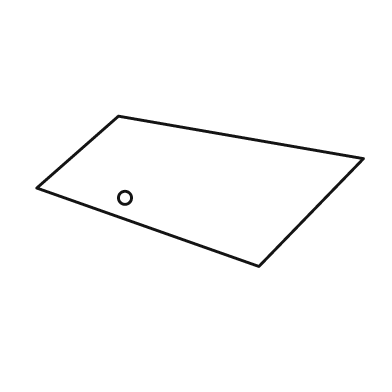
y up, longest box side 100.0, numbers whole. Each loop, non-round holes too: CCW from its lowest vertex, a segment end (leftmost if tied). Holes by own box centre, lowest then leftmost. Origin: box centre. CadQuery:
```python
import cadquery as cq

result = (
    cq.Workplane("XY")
    .moveTo(18.0, -23.0)
    .lineTo(50.0, 10.0)
    .lineTo(-25.0, 23.0)
    .lineTo(-50.0, 1.0)
    .close()
    .moveTo(-23.0, -2.0)
    .circle(2.0)
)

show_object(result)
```